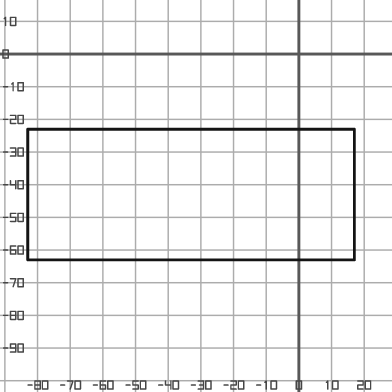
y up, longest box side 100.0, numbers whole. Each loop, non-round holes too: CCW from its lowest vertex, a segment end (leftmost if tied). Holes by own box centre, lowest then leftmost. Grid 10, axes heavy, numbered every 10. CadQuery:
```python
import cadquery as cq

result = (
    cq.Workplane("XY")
    .moveTo(-83.0, -63.0)
    .lineTo(17.0, -63.0)
    .lineTo(17.0, -23.0)
    .lineTo(-83.0, -23.0)
    .close()
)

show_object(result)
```